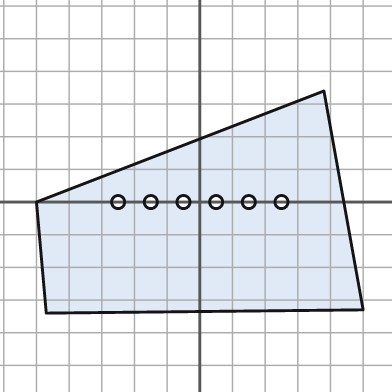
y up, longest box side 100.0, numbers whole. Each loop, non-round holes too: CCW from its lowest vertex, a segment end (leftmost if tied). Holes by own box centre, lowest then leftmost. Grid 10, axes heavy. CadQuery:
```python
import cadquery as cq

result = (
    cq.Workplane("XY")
    .moveTo(-47.0, -34.0)
    .lineTo(50.0, -33.0)
    .lineTo(38.0, 34.0)
    .lineTo(-50.0, 0.0)
    .close()
    .moveTo(-25.0, 0.0)
    .circle(2.0)
    .moveTo(-15.0, 0.0)
    .circle(2.0)
    .moveTo(-5.0, 0.0)
    .circle(2.0)
    .moveTo(5.0, 0.0)
    .circle(2.0)
    .moveTo(15.0, 0.0)
    .circle(2.0)
    .moveTo(25.0, 0.0)
    .circle(2.0)
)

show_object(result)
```